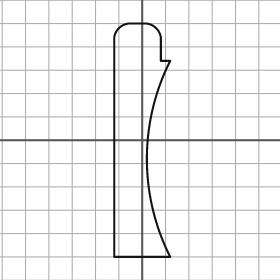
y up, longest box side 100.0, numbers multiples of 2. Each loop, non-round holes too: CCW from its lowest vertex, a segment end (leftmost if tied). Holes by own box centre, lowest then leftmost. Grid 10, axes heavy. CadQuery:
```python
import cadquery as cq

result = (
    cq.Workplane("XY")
    .moveTo(-12.0, -50.0)
    .lineTo(12.0, -50.0)
    .threePointArc((2.0, -8.0), (12.0, 34.0))
    .lineTo(8.0, 34.0)
    .lineTo(8.0, 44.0)
    .threePointArc((6.0, 48.0), (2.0, 50.0))
    .lineTo(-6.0, 50.0)
    .threePointArc((-10.0, 48.0), (-12.0, 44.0))
    .close()
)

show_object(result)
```